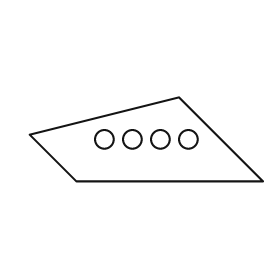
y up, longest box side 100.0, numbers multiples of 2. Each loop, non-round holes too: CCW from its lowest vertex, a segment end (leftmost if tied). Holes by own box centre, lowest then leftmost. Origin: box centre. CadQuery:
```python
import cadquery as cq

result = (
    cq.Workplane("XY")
    .moveTo(-30.0, -18.0)
    .lineTo(50.0, -18.0)
    .lineTo(14.0, 18.0)
    .lineTo(-50.0, 2.0)
    .close()
    .moveTo(-18.0, 0.0)
    .circle(4.0)
    .moveTo(-6.0, 0.0)
    .circle(4.0)
    .moveTo(6.0, 0.0)
    .circle(4.0)
    .moveTo(18.0, 0.0)
    .circle(4.0)
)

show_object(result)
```